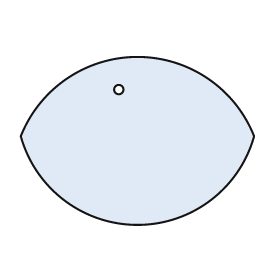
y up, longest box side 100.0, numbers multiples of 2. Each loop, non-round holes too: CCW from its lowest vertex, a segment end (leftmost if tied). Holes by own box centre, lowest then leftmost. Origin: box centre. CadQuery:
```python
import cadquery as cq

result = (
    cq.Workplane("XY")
    .moveTo(-50.0, 2.0)
    .threePointArc((0.0, -36.0), (50.0, 2.0))
    .threePointArc((0.0, 36.0), (-50.0, 2.0))
    .close()
    .moveTo(-8.0, 22.0)
    .circle(2.0)
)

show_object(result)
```